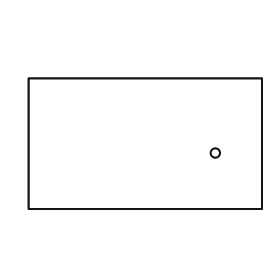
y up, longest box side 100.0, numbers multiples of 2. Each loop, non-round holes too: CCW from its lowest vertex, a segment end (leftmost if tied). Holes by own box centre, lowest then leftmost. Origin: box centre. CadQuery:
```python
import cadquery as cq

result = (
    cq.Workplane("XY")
    .moveTo(-50.0, -28.0)
    .lineTo(50.0, -28.0)
    .lineTo(50.0, 28.0)
    .lineTo(-50.0, 28.0)
    .close()
    .moveTo(30.0, -4.0)
    .circle(2.0)
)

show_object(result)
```